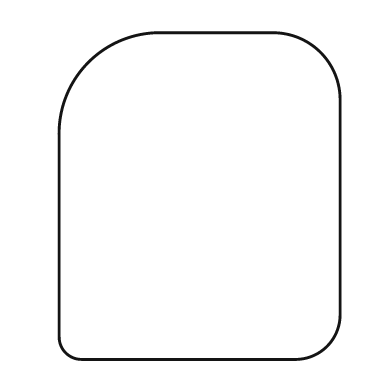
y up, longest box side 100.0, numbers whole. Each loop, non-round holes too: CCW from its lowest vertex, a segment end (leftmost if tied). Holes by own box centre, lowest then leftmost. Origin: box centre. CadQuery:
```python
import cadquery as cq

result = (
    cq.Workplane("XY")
    .moveTo(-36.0, -50.0)
    .lineTo(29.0, -50.0)
    .threePointArc((39.0, -46.0), (43.0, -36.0))
    .lineTo(43.0, 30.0)
    .threePointArc((37.0, 44.0), (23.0, 50.0))
    .lineTo(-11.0, 50.0)
    .threePointArc((-34.0, 41.0), (-43.0, 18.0))
    .lineTo(-43.0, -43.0)
    .threePointArc((-41.0, -48.0), (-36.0, -50.0))
    .close()
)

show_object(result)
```